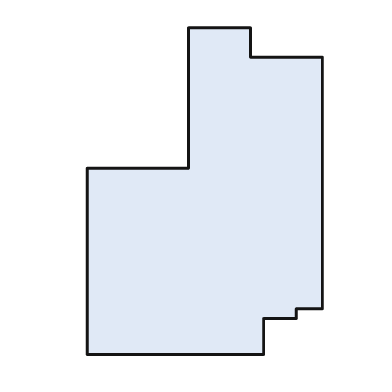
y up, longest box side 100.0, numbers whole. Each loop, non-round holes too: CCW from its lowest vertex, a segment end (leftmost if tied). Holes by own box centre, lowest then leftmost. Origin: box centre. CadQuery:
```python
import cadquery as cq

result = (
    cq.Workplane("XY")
    .moveTo(-36.0, -50.0)
    .lineTo(18.0, -50.0)
    .lineTo(18.0, -39.0)
    .lineTo(28.0, -39.0)
    .lineTo(28.0, -36.0)
    .lineTo(36.0, -36.0)
    .lineTo(36.0, 41.0)
    .lineTo(14.0, 41.0)
    .lineTo(14.0, 50.0)
    .lineTo(-5.0, 50.0)
    .lineTo(-5.0, 7.0)
    .lineTo(-36.0, 7.0)
    .close()
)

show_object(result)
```